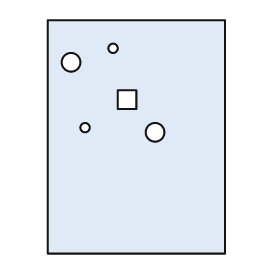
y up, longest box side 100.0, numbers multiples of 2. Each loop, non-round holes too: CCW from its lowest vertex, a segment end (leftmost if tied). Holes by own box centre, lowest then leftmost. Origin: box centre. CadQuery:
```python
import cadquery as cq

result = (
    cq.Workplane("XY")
    .moveTo(-38.0, -50.0)
    .lineTo(38.0, -50.0)
    .lineTo(38.0, 50.0)
    .lineTo(-38.0, 50.0)
    .close()
    .moveTo(8.0, 2.0)
    .circle(4.0)
    .moveTo(-22.0, 4.0)
    .circle(2.0)
    .moveTo(-8.0, 12.0)
    .lineTo(0.0, 12.0)
    .lineTo(0.0, 20.0)
    .lineTo(-8.0, 20.0)
    .close()
    .moveTo(-28.0, 32.0)
    .circle(4.0)
    .moveTo(-10.0, 38.0)
    .circle(2.0)
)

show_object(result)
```